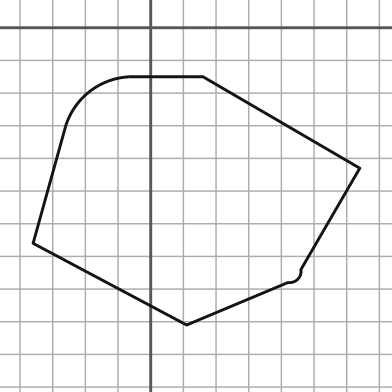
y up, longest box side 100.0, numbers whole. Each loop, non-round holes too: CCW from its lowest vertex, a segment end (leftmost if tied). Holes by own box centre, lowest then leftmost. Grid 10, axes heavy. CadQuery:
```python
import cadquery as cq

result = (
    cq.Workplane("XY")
    .moveTo(11.0, -91.0)
    .lineTo(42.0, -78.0)
    .threePointArc((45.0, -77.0), (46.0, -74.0))
    .lineTo(64.0, -43.0)
    .lineTo(16.0, -15.0)
    .lineTo(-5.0, -15.0)
    .threePointArc((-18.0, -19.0), (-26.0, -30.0))
    .lineTo(-36.0, -66.0)
    .close()
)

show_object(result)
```